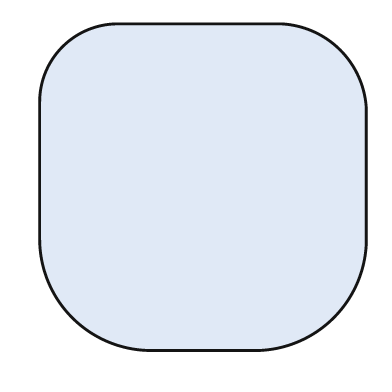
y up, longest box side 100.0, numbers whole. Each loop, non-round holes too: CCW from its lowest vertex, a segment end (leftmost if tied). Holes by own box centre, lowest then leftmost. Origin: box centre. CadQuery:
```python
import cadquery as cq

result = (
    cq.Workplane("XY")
    .moveTo(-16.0, -50.0)
    .lineTo(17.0, -50.0)
    .threePointArc((40.0, -40.0), (50.0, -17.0))
    .lineTo(50.0, 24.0)
    .threePointArc((42.0, 42.0), (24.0, 50.0))
    .lineTo(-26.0, 50.0)
    .threePointArc((-43.0, 43.0), (-50.0, 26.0))
    .lineTo(-50.0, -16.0)
    .threePointArc((-40.0, -40.0), (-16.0, -50.0))
    .close()
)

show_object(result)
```